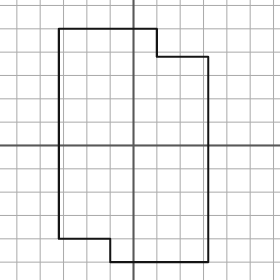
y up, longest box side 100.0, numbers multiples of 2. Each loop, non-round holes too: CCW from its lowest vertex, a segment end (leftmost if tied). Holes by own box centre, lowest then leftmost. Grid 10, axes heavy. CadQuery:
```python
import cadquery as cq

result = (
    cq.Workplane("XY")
    .moveTo(-10.0, -50.0)
    .lineTo(32.0, -50.0)
    .lineTo(32.0, 38.0)
    .lineTo(10.0, 38.0)
    .lineTo(10.0, 50.0)
    .lineTo(-32.0, 50.0)
    .lineTo(-32.0, -40.0)
    .lineTo(-10.0, -40.0)
    .close()
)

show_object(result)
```